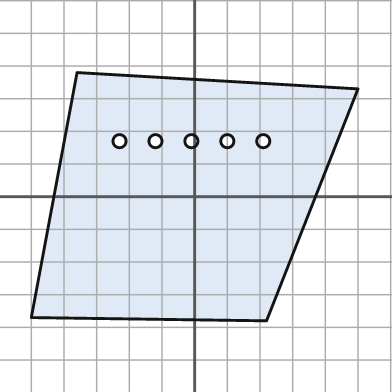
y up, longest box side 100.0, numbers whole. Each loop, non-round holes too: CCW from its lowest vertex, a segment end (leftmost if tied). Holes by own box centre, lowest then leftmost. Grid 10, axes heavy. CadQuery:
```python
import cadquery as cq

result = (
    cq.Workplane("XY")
    .moveTo(22.0, -38.0)
    .lineTo(50.0, 33.0)
    .lineTo(-36.0, 38.0)
    .lineTo(-50.0, -37.0)
    .close()
    .moveTo(-23.0, 17.0)
    .circle(2.0)
    .moveTo(-12.0, 17.0)
    .circle(2.0)
    .moveTo(-1.0, 17.0)
    .circle(2.0)
    .moveTo(10.0, 17.0)
    .circle(2.0)
    .moveTo(21.0, 17.0)
    .circle(2.0)
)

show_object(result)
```